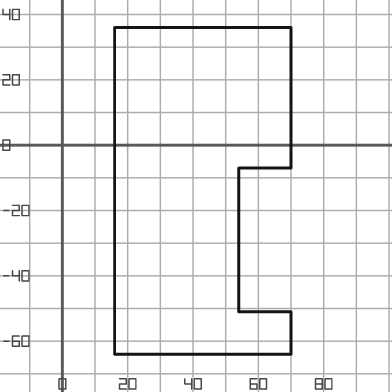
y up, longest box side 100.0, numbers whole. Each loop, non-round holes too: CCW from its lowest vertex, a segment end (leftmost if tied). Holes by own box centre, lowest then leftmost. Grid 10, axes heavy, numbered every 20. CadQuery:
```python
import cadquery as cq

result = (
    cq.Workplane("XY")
    .moveTo(16.0, -64.0)
    .lineTo(70.0, -64.0)
    .lineTo(70.0, -51.0)
    .lineTo(54.0, -51.0)
    .lineTo(54.0, -7.0)
    .lineTo(70.0, -7.0)
    .lineTo(70.0, 36.0)
    .lineTo(16.0, 36.0)
    .close()
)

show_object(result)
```